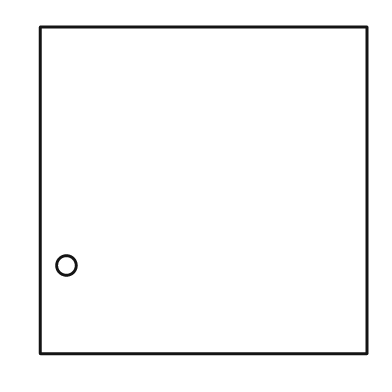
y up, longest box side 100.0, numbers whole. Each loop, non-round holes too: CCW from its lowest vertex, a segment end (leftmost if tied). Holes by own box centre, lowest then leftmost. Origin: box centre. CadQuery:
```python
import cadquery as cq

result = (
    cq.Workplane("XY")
    .moveTo(-50.0, -50.0)
    .lineTo(50.0, -50.0)
    .lineTo(50.0, 50.0)
    .lineTo(-50.0, 50.0)
    .close()
    .moveTo(-42.0, -23.0)
    .circle(3.0)
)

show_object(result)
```